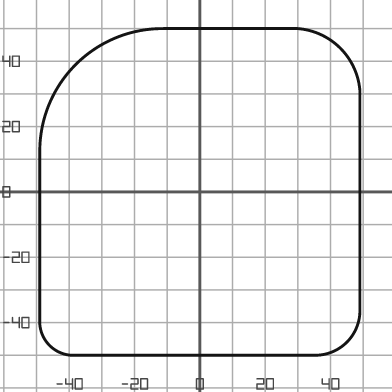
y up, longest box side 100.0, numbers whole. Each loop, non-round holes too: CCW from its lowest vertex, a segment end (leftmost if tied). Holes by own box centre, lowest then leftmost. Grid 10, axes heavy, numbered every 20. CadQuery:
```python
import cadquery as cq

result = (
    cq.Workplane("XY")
    .moveTo(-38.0, -50.0)
    .lineTo(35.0, -50.0)
    .threePointArc((45.0, -46.0), (49.0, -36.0))
    .lineTo(49.0, 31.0)
    .threePointArc((43.0, 44.0), (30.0, 50.0))
    .lineTo(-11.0, 50.0)
    .threePointArc((-38.0, 39.0), (-49.0, 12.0))
    .lineTo(-49.0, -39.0)
    .threePointArc((-46.0, -47.0), (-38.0, -50.0))
    .close()
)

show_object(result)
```